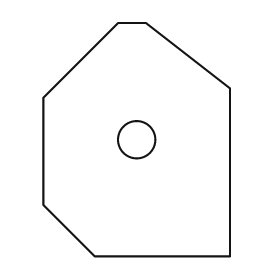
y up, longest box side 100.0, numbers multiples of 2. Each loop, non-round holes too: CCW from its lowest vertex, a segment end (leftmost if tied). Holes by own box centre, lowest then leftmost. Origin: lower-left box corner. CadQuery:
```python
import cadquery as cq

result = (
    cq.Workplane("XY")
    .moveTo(22.0, 0.0)
    .lineTo(80.0, 0.0)
    .lineTo(80.0, 72.0)
    .lineTo(44.0, 100.0)
    .lineTo(32.0, 100.0)
    .lineTo(0.0, 68.0)
    .lineTo(0.0, 22.0)
    .close()
    .moveTo(40.0, 50.0)
    .circle(8.0)
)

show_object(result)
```